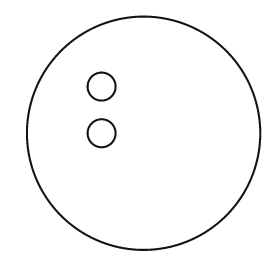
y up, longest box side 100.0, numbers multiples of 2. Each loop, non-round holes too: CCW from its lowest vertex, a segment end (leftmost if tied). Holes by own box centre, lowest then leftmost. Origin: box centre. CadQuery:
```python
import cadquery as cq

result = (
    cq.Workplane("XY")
    .moveTo(0.0, 0.0)
    .circle(50.0)
    .moveTo(-18.0, 0.0)
    .circle(6.0)
    .moveTo(-18.0, 20.0)
    .circle(6.0)
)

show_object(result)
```